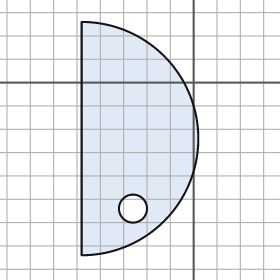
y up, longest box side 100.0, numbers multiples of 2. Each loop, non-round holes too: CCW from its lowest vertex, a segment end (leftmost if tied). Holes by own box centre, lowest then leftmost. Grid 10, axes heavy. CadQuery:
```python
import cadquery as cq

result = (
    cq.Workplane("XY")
    .moveTo(-48.0, -74.0)
    .threePointArc((2.0, -24.0), (-48.0, 26.0))
    .close()
    .moveTo(-26.0, -54.0)
    .circle(6.0)
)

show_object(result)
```